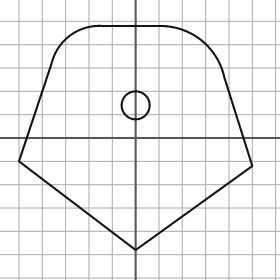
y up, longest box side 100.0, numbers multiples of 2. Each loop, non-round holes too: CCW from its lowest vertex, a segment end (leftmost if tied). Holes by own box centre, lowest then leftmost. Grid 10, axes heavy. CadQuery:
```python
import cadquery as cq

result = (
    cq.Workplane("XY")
    .moveTo(0.0, -48.0)
    .lineTo(50.0, -12.0)
    .lineTo(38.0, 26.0)
    .threePointArc((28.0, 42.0), (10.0, 48.0))
    .lineTo(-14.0, 48.0)
    .threePointArc((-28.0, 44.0), (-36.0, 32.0))
    .lineTo(-50.0, -10.0)
    .close()
    .moveTo(0.0, 14.0)
    .circle(6.0)
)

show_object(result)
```